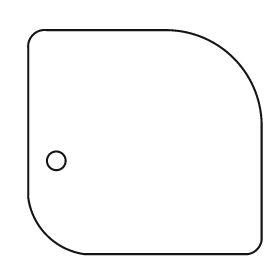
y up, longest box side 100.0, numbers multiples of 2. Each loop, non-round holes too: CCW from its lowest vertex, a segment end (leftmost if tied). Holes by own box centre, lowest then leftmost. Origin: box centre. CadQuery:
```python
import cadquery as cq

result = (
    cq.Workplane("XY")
    .moveTo(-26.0, -48.0)
    .lineTo(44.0, -48.0)
    .threePointArc((48.0, -46.0), (50.0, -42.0))
    .lineTo(50.0, 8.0)
    .threePointArc((38.0, 36.0), (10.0, 48.0))
    .lineTo(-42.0, 48.0)
    .threePointArc((-48.0, 46.0), (-50.0, 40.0))
    .lineTo(-50.0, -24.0)
    .threePointArc((-42.0, -40.0), (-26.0, -48.0))
    .close()
    .moveTo(-38.0, -8.0)
    .circle(4.0)
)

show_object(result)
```